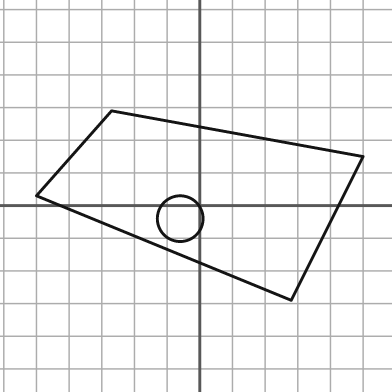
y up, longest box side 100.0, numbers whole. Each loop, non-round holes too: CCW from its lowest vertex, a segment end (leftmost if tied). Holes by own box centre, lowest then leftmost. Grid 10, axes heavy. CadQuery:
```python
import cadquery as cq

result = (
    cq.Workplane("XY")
    .moveTo(28.0, -29.0)
    .lineTo(50.0, 15.0)
    .lineTo(-27.0, 29.0)
    .lineTo(-50.0, 3.0)
    .close()
    .moveTo(-6.0, -4.0)
    .circle(7.0)
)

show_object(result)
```